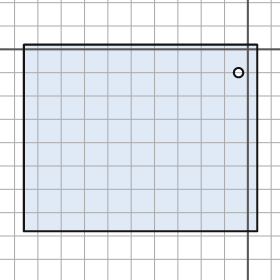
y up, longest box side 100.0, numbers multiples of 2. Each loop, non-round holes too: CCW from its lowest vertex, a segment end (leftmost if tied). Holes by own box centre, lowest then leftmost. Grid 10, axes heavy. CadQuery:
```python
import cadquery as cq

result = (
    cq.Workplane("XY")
    .moveTo(-96.0, -78.0)
    .lineTo(4.0, -78.0)
    .lineTo(4.0, 2.0)
    .lineTo(-96.0, 2.0)
    .close()
    .moveTo(-4.0, -10.0)
    .circle(2.0)
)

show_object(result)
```